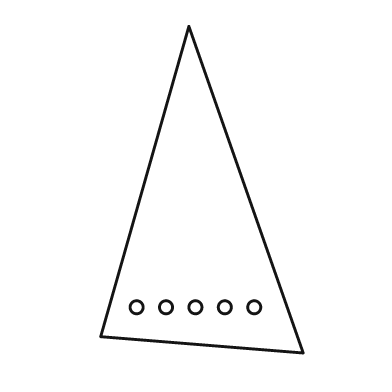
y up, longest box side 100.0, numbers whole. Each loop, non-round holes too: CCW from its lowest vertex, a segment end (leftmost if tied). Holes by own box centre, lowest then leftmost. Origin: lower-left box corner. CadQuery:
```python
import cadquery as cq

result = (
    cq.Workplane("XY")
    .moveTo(62.0, 0.0)
    .lineTo(27.0, 100.0)
    .lineTo(0.0, 5.0)
    .close()
    .moveTo(11.0, 14.0)
    .circle(2.0)
    .moveTo(20.0, 14.0)
    .circle(2.0)
    .moveTo(29.0, 14.0)
    .circle(2.0)
    .moveTo(38.0, 14.0)
    .circle(2.0)
    .moveTo(47.0, 14.0)
    .circle(2.0)
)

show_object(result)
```